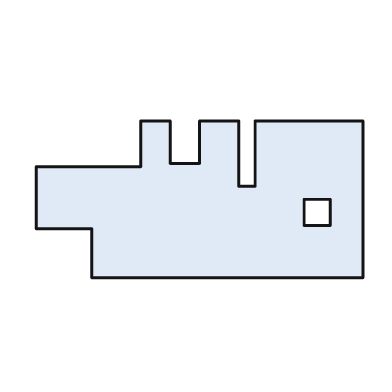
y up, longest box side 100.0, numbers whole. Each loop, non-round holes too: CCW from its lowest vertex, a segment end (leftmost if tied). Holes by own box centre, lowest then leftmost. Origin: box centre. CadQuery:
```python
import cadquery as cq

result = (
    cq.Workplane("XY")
    .moveTo(-33.0, -24.0)
    .lineTo(50.0, -24.0)
    .lineTo(50.0, 24.0)
    .lineTo(17.0, 24.0)
    .lineTo(17.0, 4.0)
    .lineTo(12.0, 4.0)
    .lineTo(12.0, 24.0)
    .lineTo(0.0, 24.0)
    .lineTo(0.0, 11.0)
    .lineTo(-9.0, 11.0)
    .lineTo(-9.0, 24.0)
    .lineTo(-18.0, 24.0)
    .lineTo(-18.0, 10.0)
    .lineTo(-50.0, 10.0)
    .lineTo(-50.0, -9.0)
    .lineTo(-33.0, -9.0)
    .close()
    .moveTo(32.0, -8.0)
    .lineTo(40.0, -8.0)
    .lineTo(40.0, 0.0)
    .lineTo(32.0, 0.0)
    .close()
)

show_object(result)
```